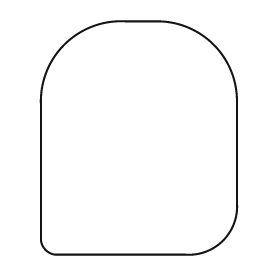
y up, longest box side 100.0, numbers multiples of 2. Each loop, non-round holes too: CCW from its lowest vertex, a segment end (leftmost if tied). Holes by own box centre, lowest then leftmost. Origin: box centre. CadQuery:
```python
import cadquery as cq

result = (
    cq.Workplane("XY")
    .moveTo(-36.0, -50.0)
    .lineTo(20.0, -50.0)
    .threePointArc((36.0, -44.0), (42.0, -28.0))
    .lineTo(42.0, 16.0)
    .threePointArc((32.0, 40.0), (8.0, 50.0))
    .lineTo(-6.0, 50.0)
    .threePointArc((-32.0, 40.0), (-42.0, 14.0))
    .lineTo(-42.0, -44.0)
    .threePointArc((-40.0, -48.0), (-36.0, -50.0))
    .close()
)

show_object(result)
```